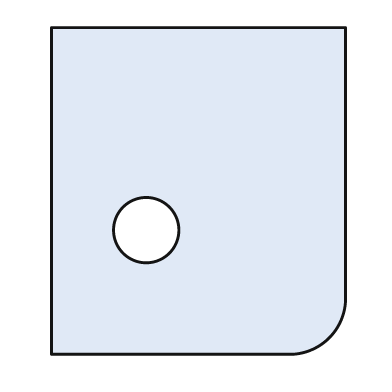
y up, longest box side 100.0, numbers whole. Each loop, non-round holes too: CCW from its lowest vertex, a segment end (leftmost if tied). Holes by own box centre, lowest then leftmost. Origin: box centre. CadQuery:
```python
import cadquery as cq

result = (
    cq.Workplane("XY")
    .moveTo(-45.0, -50.0)
    .lineTo(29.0, -50.0)
    .threePointArc((40.0, -45.0), (45.0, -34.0))
    .lineTo(45.0, 50.0)
    .lineTo(-45.0, 50.0)
    .close()
    .moveTo(-16.0, -12.0)
    .circle(10.0)
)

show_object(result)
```